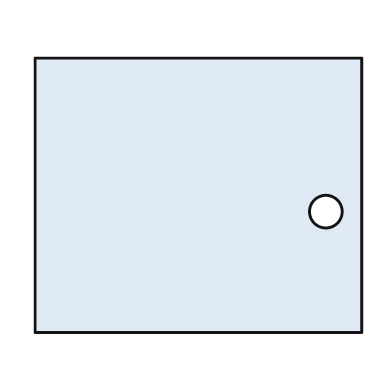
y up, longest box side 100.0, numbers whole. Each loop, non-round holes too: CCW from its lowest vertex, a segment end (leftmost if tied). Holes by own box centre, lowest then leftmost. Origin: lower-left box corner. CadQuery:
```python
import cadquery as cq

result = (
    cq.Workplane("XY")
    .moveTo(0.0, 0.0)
    .lineTo(100.0, 0.0)
    .lineTo(100.0, 84.0)
    .lineTo(0.0, 84.0)
    .close()
    .moveTo(89.0, 37.0)
    .circle(5.0)
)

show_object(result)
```